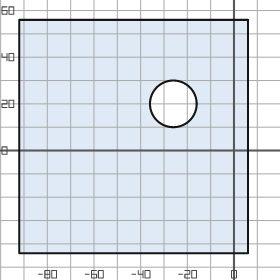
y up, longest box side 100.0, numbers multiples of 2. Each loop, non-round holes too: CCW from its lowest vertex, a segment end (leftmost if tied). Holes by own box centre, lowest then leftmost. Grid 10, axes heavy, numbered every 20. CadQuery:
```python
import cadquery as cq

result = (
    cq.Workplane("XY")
    .moveTo(-92.0, -44.0)
    .lineTo(6.0, -44.0)
    .lineTo(6.0, 56.0)
    .lineTo(-92.0, 56.0)
    .close()
    .moveTo(-26.0, 20.0)
    .circle(10.0)
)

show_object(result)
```